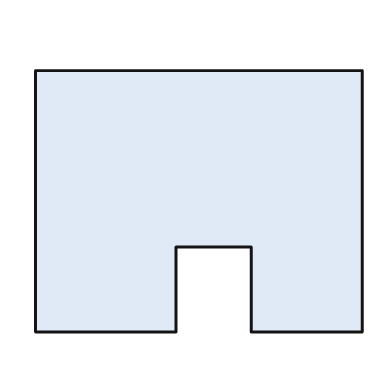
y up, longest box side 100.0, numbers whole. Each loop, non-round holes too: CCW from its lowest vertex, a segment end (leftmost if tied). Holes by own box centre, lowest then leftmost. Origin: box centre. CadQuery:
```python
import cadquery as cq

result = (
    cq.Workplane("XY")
    .moveTo(-50.0, -40.0)
    .lineTo(-7.0, -40.0)
    .lineTo(-7.0, -14.0)
    .lineTo(16.0, -14.0)
    .lineTo(16.0, -40.0)
    .lineTo(50.0, -40.0)
    .lineTo(50.0, 40.0)
    .lineTo(-50.0, 40.0)
    .close()
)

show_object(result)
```